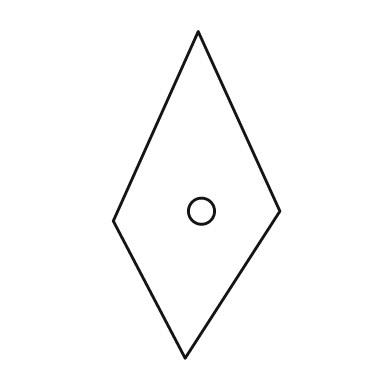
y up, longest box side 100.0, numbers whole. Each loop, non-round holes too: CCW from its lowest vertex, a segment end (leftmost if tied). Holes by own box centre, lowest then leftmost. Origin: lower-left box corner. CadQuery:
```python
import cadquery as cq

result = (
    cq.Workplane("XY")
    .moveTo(22.0, 0.0)
    .lineTo(51.0, 45.0)
    .lineTo(26.0, 100.0)
    .lineTo(0.0, 42.0)
    .close()
    .moveTo(27.0, 45.0)
    .circle(4.0)
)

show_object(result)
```